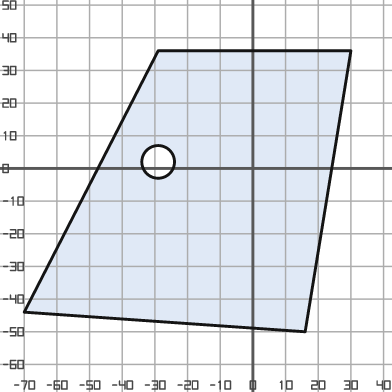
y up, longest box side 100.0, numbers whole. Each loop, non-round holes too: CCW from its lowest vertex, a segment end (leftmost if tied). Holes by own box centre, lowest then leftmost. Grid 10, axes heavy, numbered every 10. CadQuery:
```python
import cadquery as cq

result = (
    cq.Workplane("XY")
    .moveTo(16.0, -50.0)
    .lineTo(30.0, 36.0)
    .lineTo(-29.0, 36.0)
    .lineTo(-70.0, -44.0)
    .close()
    .moveTo(-29.0, 2.0)
    .circle(5.0)
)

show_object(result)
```